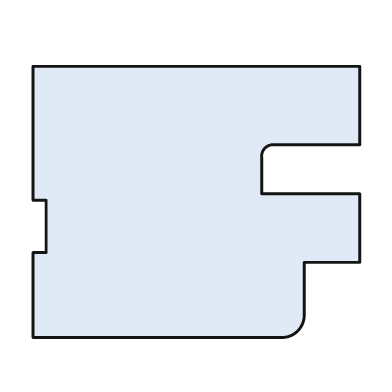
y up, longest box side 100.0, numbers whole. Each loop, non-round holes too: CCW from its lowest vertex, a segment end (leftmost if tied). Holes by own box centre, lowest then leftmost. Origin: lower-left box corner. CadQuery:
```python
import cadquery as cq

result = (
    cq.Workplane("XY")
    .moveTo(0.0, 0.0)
    .lineTo(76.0, 0.0)
    .threePointArc((81.0, 2.0), (83.0, 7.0))
    .lineTo(83.0, 23.0)
    .lineTo(100.0, 23.0)
    .lineTo(100.0, 44.0)
    .lineTo(70.0, 44.0)
    .lineTo(70.0, 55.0)
    .threePointArc((71.0, 58.0), (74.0, 59.0))
    .lineTo(100.0, 59.0)
    .lineTo(100.0, 83.0)
    .lineTo(0.0, 83.0)
    .lineTo(0.0, 42.0)
    .lineTo(4.0, 42.0)
    .lineTo(4.0, 26.0)
    .lineTo(0.0, 26.0)
    .close()
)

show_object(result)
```